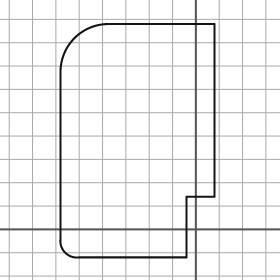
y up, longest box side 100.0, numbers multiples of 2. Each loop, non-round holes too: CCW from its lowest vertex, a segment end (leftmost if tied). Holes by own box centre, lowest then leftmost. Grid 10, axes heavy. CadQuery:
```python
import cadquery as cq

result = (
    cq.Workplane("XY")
    .moveTo(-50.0, -12.0)
    .lineTo(-4.0, -12.0)
    .lineTo(-4.0, 14.0)
    .lineTo(8.0, 14.0)
    .lineTo(8.0, 88.0)
    .lineTo(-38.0, 88.0)
    .threePointArc((-52.0, 82.0), (-58.0, 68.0))
    .lineTo(-58.0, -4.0)
    .threePointArc((-56.0, -10.0), (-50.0, -12.0))
    .close()
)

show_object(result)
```